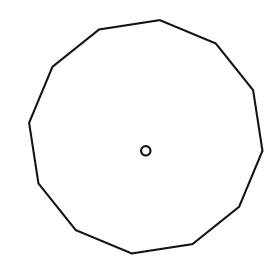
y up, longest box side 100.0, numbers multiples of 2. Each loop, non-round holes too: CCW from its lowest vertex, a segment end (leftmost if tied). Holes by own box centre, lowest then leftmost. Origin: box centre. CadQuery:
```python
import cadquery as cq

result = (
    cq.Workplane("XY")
    .moveTo(-6.0, -50.0)
    .lineTo(20.0, -46.0)
    .lineTo(40.0, -30.0)
    .lineTo(50.0, -6.0)
    .lineTo(46.0, 20.0)
    .lineTo(30.0, 40.0)
    .lineTo(6.0, 50.0)
    .lineTo(-20.0, 46.0)
    .lineTo(-40.0, 30.0)
    .lineTo(-50.0, 6.0)
    .lineTo(-46.0, -20.0)
    .lineTo(-30.0, -40.0)
    .close()
    .moveTo(0.0, -6.0)
    .circle(2.0)
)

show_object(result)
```